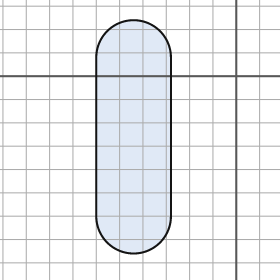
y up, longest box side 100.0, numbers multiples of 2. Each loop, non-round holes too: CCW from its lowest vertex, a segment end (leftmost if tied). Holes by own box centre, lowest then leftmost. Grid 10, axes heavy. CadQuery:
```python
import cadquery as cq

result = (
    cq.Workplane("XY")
    .moveTo(-60.0, -60.0)
    .threePointArc((-44.0, -76.0), (-28.0, -60.0))
    .lineTo(-28.0, 8.0)
    .threePointArc((-44.0, 24.0), (-60.0, 8.0))
    .close()
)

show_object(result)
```